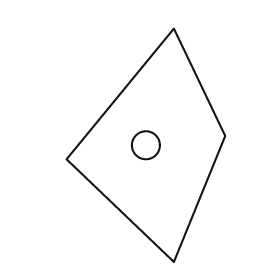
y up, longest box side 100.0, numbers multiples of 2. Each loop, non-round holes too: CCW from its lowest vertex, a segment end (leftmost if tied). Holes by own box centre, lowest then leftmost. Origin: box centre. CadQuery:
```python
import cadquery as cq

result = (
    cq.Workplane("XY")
    .moveTo(12.0, -50.0)
    .lineTo(34.0, 4.0)
    .lineTo(12.0, 50.0)
    .lineTo(-34.0, -6.0)
    .close()
    .moveTo(0.0, 0.0)
    .circle(6.0)
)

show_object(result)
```